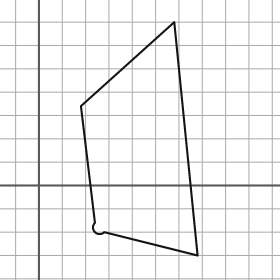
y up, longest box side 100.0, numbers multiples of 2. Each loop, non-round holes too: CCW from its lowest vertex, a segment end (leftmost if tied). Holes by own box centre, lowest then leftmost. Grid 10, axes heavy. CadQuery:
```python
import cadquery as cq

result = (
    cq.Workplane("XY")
    .moveTo(68.0, -30.0)
    .lineTo(58.0, 70.0)
    .lineTo(18.0, 34.0)
    .lineTo(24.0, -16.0)
    .threePointArc((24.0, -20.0), (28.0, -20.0))
    .close()
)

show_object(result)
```